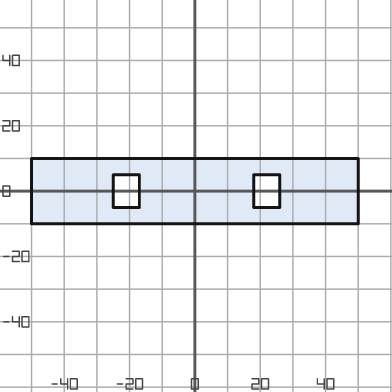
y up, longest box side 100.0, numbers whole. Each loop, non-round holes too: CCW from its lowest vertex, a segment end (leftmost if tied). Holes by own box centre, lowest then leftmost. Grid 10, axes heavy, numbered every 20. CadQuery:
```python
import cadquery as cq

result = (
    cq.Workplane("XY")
    .moveTo(-50.0, -10.0)
    .lineTo(50.0, -10.0)
    .lineTo(50.0, 10.0)
    .lineTo(-50.0, 10.0)
    .close()
    .moveTo(-25.0, -5.0)
    .lineTo(-17.0, -5.0)
    .lineTo(-17.0, 5.0)
    .lineTo(-25.0, 5.0)
    .close()
    .moveTo(18.0, -5.0)
    .lineTo(26.0, -5.0)
    .lineTo(26.0, 5.0)
    .lineTo(18.0, 5.0)
    .close()
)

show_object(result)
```